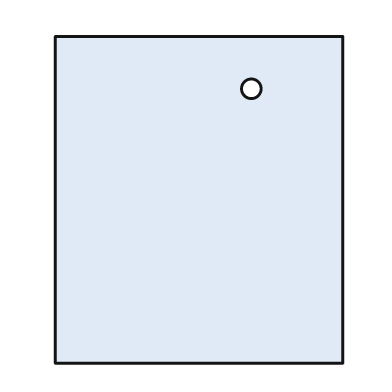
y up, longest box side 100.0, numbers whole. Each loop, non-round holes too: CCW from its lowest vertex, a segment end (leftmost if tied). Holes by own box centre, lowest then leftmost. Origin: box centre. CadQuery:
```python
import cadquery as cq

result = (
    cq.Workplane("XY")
    .moveTo(-44.0, -50.0)
    .lineTo(44.0, -50.0)
    .lineTo(44.0, 50.0)
    .lineTo(-44.0, 50.0)
    .close()
    .moveTo(16.0, 34.0)
    .circle(3.0)
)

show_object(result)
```